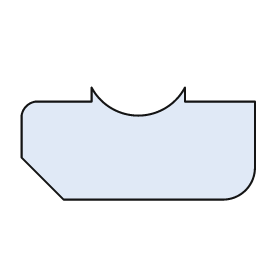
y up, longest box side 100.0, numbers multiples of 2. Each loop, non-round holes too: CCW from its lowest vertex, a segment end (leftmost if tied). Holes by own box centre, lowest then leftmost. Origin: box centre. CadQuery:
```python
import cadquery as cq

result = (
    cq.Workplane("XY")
    .moveTo(-32.0, -24.0)
    .lineTo(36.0, -24.0)
    .threePointArc((46.0, -20.0), (50.0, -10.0))
    .lineTo(50.0, 18.0)
    .lineTo(20.0, 18.0)
    .lineTo(20.0, 24.0)
    .threePointArc((0.0, 12.0), (-20.0, 24.0))
    .lineTo(-20.0, 18.0)
    .lineTo(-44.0, 18.0)
    .threePointArc((-48.0, 16.0), (-50.0, 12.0))
    .lineTo(-50.0, -6.0)
    .close()
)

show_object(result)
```